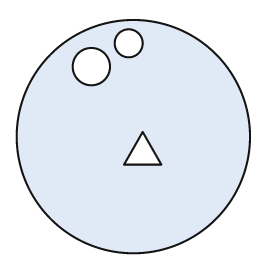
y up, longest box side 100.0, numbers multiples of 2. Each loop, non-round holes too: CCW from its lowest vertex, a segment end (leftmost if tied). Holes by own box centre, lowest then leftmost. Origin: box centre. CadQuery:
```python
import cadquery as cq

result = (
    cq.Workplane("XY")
    .moveTo(0.0, 0.0)
    .circle(50.0)
    .moveTo(-4.0, -12.0)
    .lineTo(12.0, -12.0)
    .lineTo(4.0, 2.0)
    .close()
    .moveTo(-18.0, 30.0)
    .circle(8.0)
    .moveTo(-2.0, 40.0)
    .circle(6.0)
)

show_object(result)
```